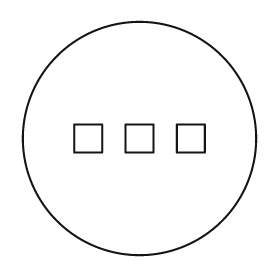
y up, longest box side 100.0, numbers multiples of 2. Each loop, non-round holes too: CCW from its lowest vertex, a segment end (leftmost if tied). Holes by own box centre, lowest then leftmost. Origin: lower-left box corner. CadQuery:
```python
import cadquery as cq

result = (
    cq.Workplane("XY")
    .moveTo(50.0, 50.0)
    .circle(50.0)
    .moveTo(22.0, 44.0)
    .lineTo(34.0, 44.0)
    .lineTo(34.0, 56.0)
    .lineTo(22.0, 56.0)
    .close()
    .moveTo(44.0, 44.0)
    .lineTo(56.0, 44.0)
    .lineTo(56.0, 56.0)
    .lineTo(44.0, 56.0)
    .close()
    .moveTo(66.0, 44.0)
    .lineTo(78.0, 44.0)
    .lineTo(78.0, 56.0)
    .lineTo(66.0, 56.0)
    .close()
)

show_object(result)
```